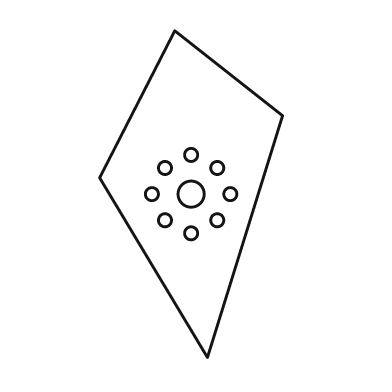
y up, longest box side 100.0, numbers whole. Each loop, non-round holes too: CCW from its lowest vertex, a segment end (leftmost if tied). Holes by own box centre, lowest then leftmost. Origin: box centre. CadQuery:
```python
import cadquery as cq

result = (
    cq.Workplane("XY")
    .moveTo(5.0, -50.0)
    .lineTo(28.0, 24.0)
    .lineTo(-5.0, 50.0)
    .lineTo(-28.0, 5.0)
    .close()
    .moveTo(0.0, -12.0)
    .circle(2.0)
    .moveTo(-8.0, -8.0)
    .circle(2.0)
    .moveTo(8.0, -8.0)
    .circle(2.0)
    .moveTo(-12.0, 0.0)
    .circle(2.0)
    .moveTo(0.0, 0.0)
    .circle(4.0)
    .moveTo(12.0, 0.0)
    .circle(2.0)
    .moveTo(-8.0, 8.0)
    .circle(2.0)
    .moveTo(8.0, 8.0)
    .circle(2.0)
    .moveTo(0.0, 12.0)
    .circle(2.0)
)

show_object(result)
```